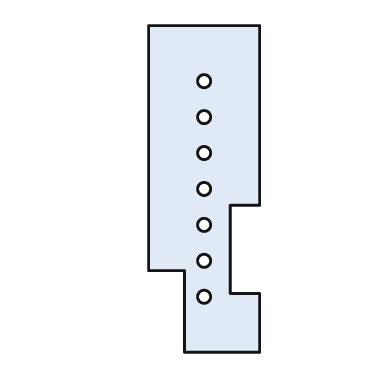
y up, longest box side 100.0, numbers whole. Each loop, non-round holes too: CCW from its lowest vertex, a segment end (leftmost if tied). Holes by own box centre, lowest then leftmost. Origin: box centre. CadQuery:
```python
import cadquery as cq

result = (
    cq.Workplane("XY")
    .moveTo(-6.0, -50.0)
    .lineTo(17.0, -50.0)
    .lineTo(17.0, -32.0)
    .lineTo(8.0, -32.0)
    .lineTo(8.0, -5.0)
    .lineTo(17.0, -5.0)
    .lineTo(17.0, 50.0)
    .lineTo(-17.0, 50.0)
    .lineTo(-17.0, -25.0)
    .lineTo(-6.0, -25.0)
    .close()
    .moveTo(0.0, -33.0)
    .circle(2.0)
    .moveTo(0.0, -22.0)
    .circle(2.0)
    .moveTo(0.0, -11.0)
    .circle(2.0)
    .moveTo(0.0, 0.0)
    .circle(2.0)
    .moveTo(0.0, 11.0)
    .circle(2.0)
    .moveTo(0.0, 22.0)
    .circle(2.0)
    .moveTo(0.0, 33.0)
    .circle(2.0)
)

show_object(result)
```